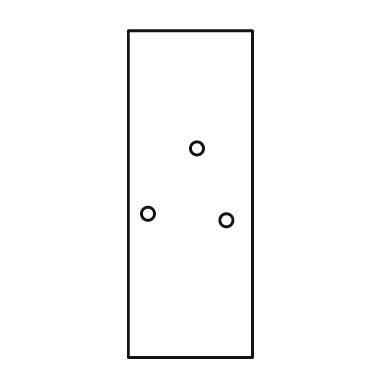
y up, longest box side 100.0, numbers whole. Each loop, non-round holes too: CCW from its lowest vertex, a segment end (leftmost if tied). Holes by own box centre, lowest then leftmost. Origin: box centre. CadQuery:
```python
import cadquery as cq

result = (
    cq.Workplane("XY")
    .moveTo(-19.0, -50.0)
    .lineTo(19.0, -50.0)
    .lineTo(19.0, 50.0)
    .lineTo(-19.0, 50.0)
    .close()
    .moveTo(11.0, -8.0)
    .circle(2.0)
    .moveTo(-13.0, -6.0)
    .circle(2.0)
    .moveTo(2.0, 14.0)
    .circle(2.0)
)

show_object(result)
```